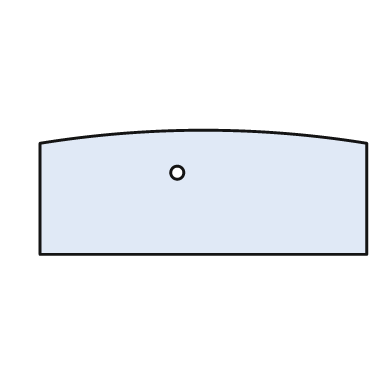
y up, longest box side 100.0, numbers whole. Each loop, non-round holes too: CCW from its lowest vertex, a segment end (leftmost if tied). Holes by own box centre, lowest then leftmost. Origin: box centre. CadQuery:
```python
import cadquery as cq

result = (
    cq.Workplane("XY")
    .moveTo(-50.0, -19.0)
    .lineTo(50.0, -19.0)
    .lineTo(50.0, 15.0)
    .threePointArc((0.0, 19.0), (-50.0, 15.0))
    .close()
    .moveTo(-8.0, 6.0)
    .circle(2.0)
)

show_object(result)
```